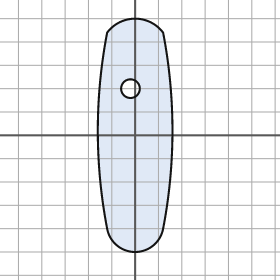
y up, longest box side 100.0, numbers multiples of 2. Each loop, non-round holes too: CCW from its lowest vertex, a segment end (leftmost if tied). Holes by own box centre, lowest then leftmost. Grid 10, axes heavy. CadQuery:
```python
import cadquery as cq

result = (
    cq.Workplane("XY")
    .moveTo(-12.0, -40.0)
    .threePointArc((0.0, -50.0), (12.0, -40.0))
    .threePointArc((16.0, 2.0), (12.0, 44.0))
    .threePointArc((0.0, 50.0), (-12.0, 44.0))
    .threePointArc((-16.0, 2.0), (-12.0, -40.0))
    .close()
    .moveTo(-2.0, 20.0)
    .circle(4.0)
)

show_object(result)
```